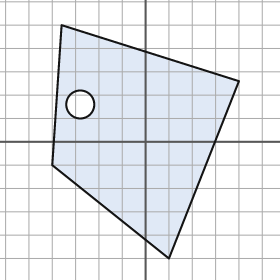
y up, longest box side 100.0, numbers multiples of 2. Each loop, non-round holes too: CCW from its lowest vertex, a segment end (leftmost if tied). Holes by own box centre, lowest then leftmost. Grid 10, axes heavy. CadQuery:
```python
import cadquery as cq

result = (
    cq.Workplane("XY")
    .moveTo(10.0, -50.0)
    .lineTo(40.0, 26.0)
    .lineTo(-36.0, 50.0)
    .lineTo(-40.0, -10.0)
    .close()
    .moveTo(-28.0, 16.0)
    .circle(6.0)
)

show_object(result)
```